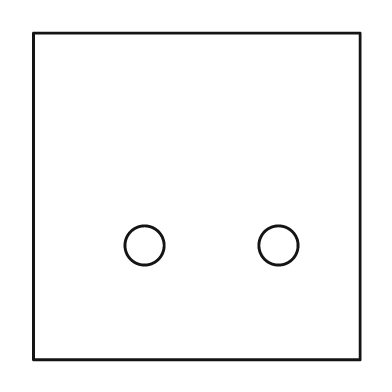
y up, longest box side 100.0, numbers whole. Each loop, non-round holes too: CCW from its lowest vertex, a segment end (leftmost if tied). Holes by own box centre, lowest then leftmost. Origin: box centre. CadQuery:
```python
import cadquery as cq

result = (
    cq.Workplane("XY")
    .moveTo(-50.0, -50.0)
    .lineTo(50.0, -50.0)
    .lineTo(50.0, 50.0)
    .lineTo(-50.0, 50.0)
    .close()
    .moveTo(-16.0, -15.0)
    .circle(6.0)
    .moveTo(25.0, -15.0)
    .circle(6.0)
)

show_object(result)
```